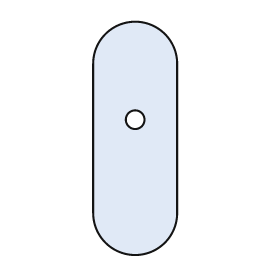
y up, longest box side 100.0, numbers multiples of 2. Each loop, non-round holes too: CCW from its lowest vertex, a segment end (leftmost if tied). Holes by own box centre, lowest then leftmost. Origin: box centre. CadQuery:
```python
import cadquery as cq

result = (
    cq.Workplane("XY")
    .moveTo(-18.0, -32.0)
    .threePointArc((0.0, -50.0), (18.0, -32.0))
    .lineTo(18.0, 32.0)
    .threePointArc((0.0, 50.0), (-18.0, 32.0))
    .close()
    .moveTo(0.0, 8.0)
    .circle(4.0)
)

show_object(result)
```